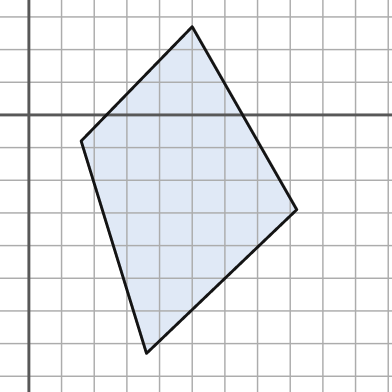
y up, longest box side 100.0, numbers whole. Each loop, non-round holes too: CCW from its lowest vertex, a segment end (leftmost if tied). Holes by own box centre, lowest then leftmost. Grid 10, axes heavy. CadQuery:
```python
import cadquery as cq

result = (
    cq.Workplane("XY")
    .moveTo(36.0, -73.0)
    .lineTo(82.0, -29.0)
    .lineTo(50.0, 27.0)
    .lineTo(16.0, -8.0)
    .close()
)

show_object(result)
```